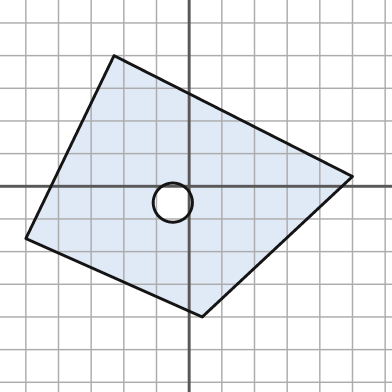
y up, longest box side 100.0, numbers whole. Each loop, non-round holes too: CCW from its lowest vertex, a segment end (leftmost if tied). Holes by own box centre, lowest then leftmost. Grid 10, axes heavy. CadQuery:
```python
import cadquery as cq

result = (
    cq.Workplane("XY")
    .moveTo(4.0, -40.0)
    .lineTo(50.0, 3.0)
    .lineTo(-23.0, 40.0)
    .lineTo(-50.0, -16.0)
    .close()
    .moveTo(-5.0, -5.0)
    .circle(6.0)
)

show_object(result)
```